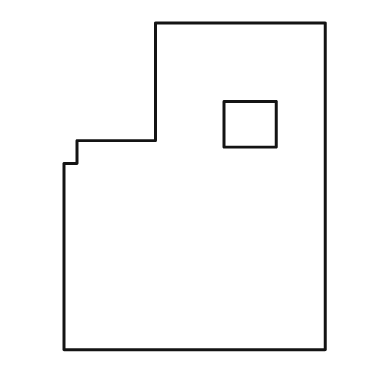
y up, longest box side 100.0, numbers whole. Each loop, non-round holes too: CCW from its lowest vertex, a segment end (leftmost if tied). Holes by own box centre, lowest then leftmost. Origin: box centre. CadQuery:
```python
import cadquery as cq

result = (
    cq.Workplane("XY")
    .moveTo(-40.0, -50.0)
    .lineTo(40.0, -50.0)
    .lineTo(40.0, 50.0)
    .lineTo(-12.0, 50.0)
    .lineTo(-12.0, 14.0)
    .lineTo(-36.0, 14.0)
    .lineTo(-36.0, 7.0)
    .lineTo(-40.0, 7.0)
    .close()
    .moveTo(9.0, 12.0)
    .lineTo(25.0, 12.0)
    .lineTo(25.0, 26.0)
    .lineTo(9.0, 26.0)
    .close()
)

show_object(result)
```